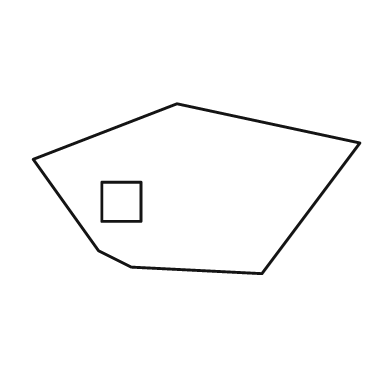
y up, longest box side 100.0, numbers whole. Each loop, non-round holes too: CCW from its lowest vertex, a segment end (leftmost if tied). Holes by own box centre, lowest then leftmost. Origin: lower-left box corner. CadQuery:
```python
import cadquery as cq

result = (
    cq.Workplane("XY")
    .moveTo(70.0, 0.0)
    .lineTo(100.0, 40.0)
    .lineTo(44.0, 52.0)
    .lineTo(0.0, 35.0)
    .lineTo(20.0, 7.0)
    .lineTo(30.0, 2.0)
    .close()
    .moveTo(21.0, 16.0)
    .lineTo(33.0, 16.0)
    .lineTo(33.0, 28.0)
    .lineTo(21.0, 28.0)
    .close()
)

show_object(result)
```